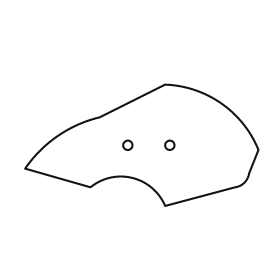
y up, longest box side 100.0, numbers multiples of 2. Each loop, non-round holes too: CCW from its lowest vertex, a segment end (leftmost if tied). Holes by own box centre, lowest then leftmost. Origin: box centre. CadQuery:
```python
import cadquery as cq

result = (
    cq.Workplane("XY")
    .moveTo(10.0, -26.0)
    .lineTo(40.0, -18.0)
    .threePointArc((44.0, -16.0), (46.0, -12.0))
    .lineTo(50.0, -2.0)
    .threePointArc((34.0, 18.0), (10.0, 26.0))
    .lineTo(-18.0, 12.0)
    .threePointArc((-36.0, 4.0), (-50.0, -10.0))
    .lineTo(-22.0, -18.0)
    .threePointArc((-4.0, -14.0), (10.0, -26.0))
    .close()
    .moveTo(-6.0, 0.0)
    .circle(2.0)
    .moveTo(12.0, 0.0)
    .circle(2.0)
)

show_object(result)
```